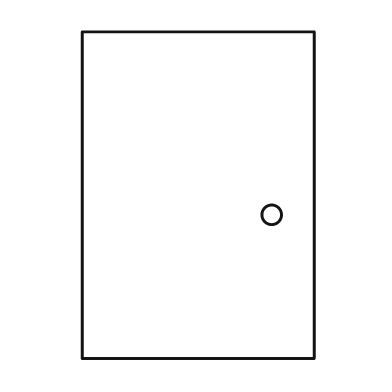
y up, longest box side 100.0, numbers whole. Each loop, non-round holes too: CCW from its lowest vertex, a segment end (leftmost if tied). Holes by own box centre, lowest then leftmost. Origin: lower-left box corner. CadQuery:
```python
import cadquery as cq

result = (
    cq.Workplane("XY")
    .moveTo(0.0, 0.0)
    .lineTo(71.0, 0.0)
    .lineTo(71.0, 100.0)
    .lineTo(0.0, 100.0)
    .close()
    .moveTo(58.0, 44.0)
    .circle(3.0)
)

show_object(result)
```